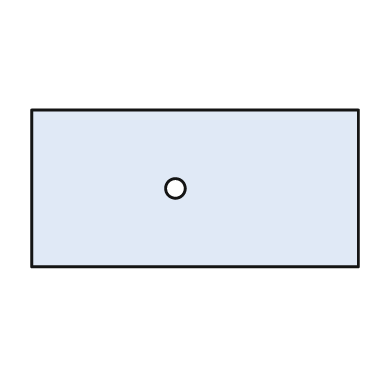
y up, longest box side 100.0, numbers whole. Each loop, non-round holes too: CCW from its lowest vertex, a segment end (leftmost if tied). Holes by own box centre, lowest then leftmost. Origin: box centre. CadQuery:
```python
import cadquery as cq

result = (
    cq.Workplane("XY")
    .moveTo(-50.0, -24.0)
    .lineTo(50.0, -24.0)
    .lineTo(50.0, 24.0)
    .lineTo(-50.0, 24.0)
    .close()
    .moveTo(-6.0, 0.0)
    .circle(3.0)
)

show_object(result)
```